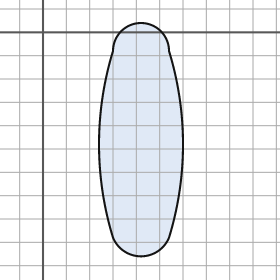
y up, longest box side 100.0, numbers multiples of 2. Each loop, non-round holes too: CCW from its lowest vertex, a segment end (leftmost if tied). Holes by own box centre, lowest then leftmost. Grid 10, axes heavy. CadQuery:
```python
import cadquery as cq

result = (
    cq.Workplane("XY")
    .moveTo(30.0, -88.0)
    .threePointArc((42.0, -96.0), (54.0, -88.0))
    .threePointArc((60.0, -48.0), (54.0, -8.0))
    .threePointArc((42.0, 4.0), (30.0, -8.0))
    .threePointArc((24.0, -48.0), (30.0, -88.0))
    .close()
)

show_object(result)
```